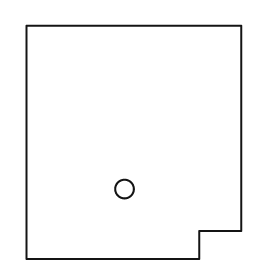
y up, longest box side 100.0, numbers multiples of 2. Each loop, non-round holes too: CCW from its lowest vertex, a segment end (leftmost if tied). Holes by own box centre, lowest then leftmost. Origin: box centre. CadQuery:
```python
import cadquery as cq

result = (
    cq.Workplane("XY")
    .moveTo(-46.0, -50.0)
    .lineTo(28.0, -50.0)
    .lineTo(28.0, -38.0)
    .lineTo(46.0, -38.0)
    .lineTo(46.0, 50.0)
    .lineTo(-46.0, 50.0)
    .close()
    .moveTo(-4.0, -20.0)
    .circle(4.0)
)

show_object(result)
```